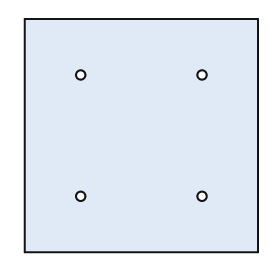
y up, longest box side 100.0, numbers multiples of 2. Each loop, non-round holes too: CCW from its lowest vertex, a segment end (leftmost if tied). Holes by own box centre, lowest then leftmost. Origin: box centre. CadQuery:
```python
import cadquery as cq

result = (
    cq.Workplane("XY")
    .moveTo(-50.0, -50.0)
    .lineTo(50.0, -50.0)
    .lineTo(50.0, 50.0)
    .lineTo(-50.0, 50.0)
    .close()
    .moveTo(-26.0, -26.0)
    .circle(2.0)
    .moveTo(26.0, -26.0)
    .circle(2.0)
    .moveTo(-26.0, 26.0)
    .circle(2.0)
    .moveTo(26.0, 26.0)
    .circle(2.0)
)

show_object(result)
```